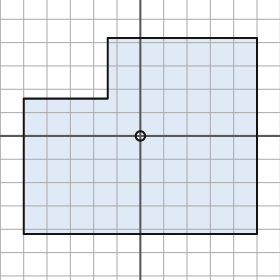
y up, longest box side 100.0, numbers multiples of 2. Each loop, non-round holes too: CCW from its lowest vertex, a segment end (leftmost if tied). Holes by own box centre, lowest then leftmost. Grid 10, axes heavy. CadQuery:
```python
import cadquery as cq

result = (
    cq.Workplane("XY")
    .moveTo(-50.0, -42.0)
    .lineTo(50.0, -42.0)
    .lineTo(50.0, 42.0)
    .lineTo(-14.0, 42.0)
    .lineTo(-14.0, 16.0)
    .lineTo(-50.0, 16.0)
    .close()
    .moveTo(0.0, 0.0)
    .circle(2.0)
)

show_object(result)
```